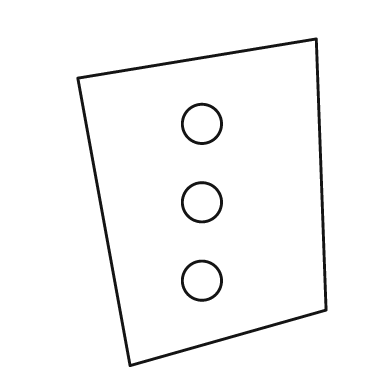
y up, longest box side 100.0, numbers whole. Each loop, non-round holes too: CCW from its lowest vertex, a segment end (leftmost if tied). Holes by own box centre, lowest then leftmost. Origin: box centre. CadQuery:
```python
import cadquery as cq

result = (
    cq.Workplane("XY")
    .moveTo(-22.0, -50.0)
    .lineTo(38.0, -33.0)
    .lineTo(35.0, 50.0)
    .lineTo(-38.0, 38.0)
    .close()
    .moveTo(0.0, -24.0)
    .circle(6.0)
    .moveTo(0.0, 0.0)
    .circle(6.0)
    .moveTo(0.0, 24.0)
    .circle(6.0)
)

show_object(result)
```